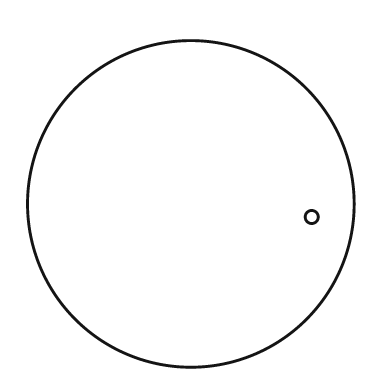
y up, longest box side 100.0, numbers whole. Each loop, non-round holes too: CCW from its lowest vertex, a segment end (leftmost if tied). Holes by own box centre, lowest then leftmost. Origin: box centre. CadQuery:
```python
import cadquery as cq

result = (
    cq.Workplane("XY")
    .moveTo(0.0, 0.0)
    .circle(50.0)
    .moveTo(37.0, -4.0)
    .circle(2.0)
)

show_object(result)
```